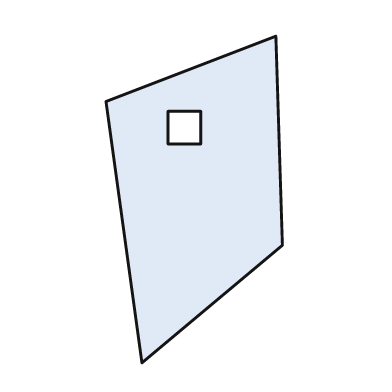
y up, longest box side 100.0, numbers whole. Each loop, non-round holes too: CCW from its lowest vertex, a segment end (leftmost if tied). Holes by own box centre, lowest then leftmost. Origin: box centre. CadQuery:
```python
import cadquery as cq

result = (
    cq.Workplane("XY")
    .moveTo(-16.0, -50.0)
    .lineTo(27.0, -14.0)
    .lineTo(25.0, 50.0)
    .lineTo(-27.0, 30.0)
    .close()
    .moveTo(-8.0, 17.0)
    .lineTo(2.0, 17.0)
    .lineTo(2.0, 27.0)
    .lineTo(-8.0, 27.0)
    .close()
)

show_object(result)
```